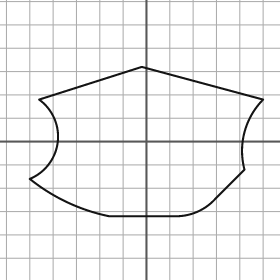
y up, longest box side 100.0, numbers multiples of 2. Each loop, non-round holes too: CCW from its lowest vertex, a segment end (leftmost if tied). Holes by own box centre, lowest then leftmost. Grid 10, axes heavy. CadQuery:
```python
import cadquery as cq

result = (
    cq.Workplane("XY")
    .moveTo(-16.0, -32.0)
    .lineTo(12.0, -32.0)
    .threePointArc((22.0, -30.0), (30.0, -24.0))
    .lineTo(42.0, -12.0)
    .threePointArc((42.0, 4.0), (50.0, 18.0))
    .lineTo(-2.0, 32.0)
    .lineTo(-46.0, 18.0)
    .threePointArc((-38.0, 0.0), (-50.0, -16.0))
    .threePointArc((-34.0, -26.0), (-16.0, -32.0))
    .close()
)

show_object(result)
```